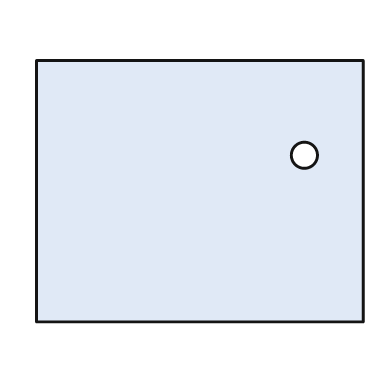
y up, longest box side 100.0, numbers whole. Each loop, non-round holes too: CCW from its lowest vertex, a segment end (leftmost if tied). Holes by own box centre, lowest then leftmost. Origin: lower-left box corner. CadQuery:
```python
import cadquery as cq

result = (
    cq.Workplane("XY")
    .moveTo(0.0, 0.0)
    .lineTo(100.0, 0.0)
    .lineTo(100.0, 80.0)
    .lineTo(0.0, 80.0)
    .close()
    .moveTo(82.0, 51.0)
    .circle(4.0)
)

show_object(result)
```